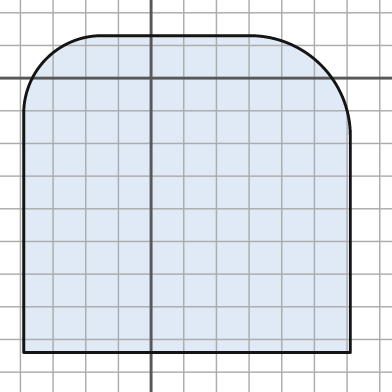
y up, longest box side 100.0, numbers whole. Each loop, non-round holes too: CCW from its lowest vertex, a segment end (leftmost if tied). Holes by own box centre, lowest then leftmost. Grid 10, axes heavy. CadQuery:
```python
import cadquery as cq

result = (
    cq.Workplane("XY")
    .moveTo(-39.0, -84.0)
    .lineTo(61.0, -84.0)
    .lineTo(61.0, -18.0)
    .threePointArc((52.0, 4.0), (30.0, 13.0))
    .lineTo(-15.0, 13.0)
    .threePointArc((-32.0, 6.0), (-39.0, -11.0))
    .close()
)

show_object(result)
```